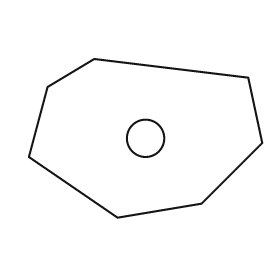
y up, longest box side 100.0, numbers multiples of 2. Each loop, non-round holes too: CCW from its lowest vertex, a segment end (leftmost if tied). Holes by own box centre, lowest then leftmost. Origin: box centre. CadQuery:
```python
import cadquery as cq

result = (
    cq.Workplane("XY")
    .moveTo(-12.0, -34.0)
    .lineTo(24.0, -28.0)
    .lineTo(50.0, -2.0)
    .lineTo(44.0, 26.0)
    .lineTo(-22.0, 34.0)
    .lineTo(-42.0, 22.0)
    .lineTo(-50.0, -8.0)
    .close()
    .moveTo(0.0, 0.0)
    .circle(8.0)
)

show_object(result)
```